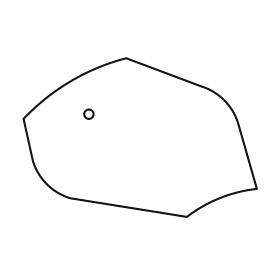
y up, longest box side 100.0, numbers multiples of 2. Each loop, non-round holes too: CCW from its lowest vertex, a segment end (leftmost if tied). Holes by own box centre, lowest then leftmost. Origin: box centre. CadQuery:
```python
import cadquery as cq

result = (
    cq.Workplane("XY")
    .moveTo(20.0, -34.0)
    .threePointArc((34.0, -26.0), (50.0, -22.0))
    .lineTo(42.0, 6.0)
    .threePointArc((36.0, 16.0), (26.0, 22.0))
    .lineTo(-6.0, 34.0)
    .threePointArc((-30.0, 24.0), (-50.0, 8.0))
    .lineTo(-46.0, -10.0)
    .threePointArc((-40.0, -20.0), (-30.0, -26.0))
    .close()
    .moveTo(-22.0, 10.0)
    .circle(2.0)
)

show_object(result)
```